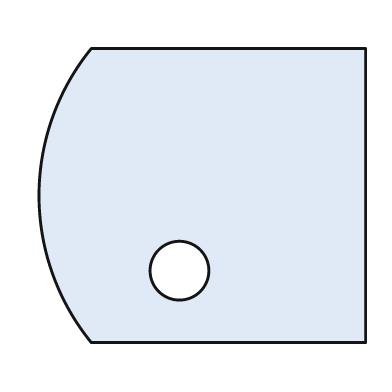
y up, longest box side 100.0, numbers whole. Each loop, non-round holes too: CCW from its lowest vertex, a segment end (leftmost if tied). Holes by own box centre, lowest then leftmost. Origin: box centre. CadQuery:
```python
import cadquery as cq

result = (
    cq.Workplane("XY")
    .moveTo(-34.0, -45.0)
    .lineTo(50.0, -45.0)
    .lineTo(50.0, 45.0)
    .lineTo(-34.0, 45.0)
    .threePointArc((-50.0, 0.0), (-34.0, -45.0))
    .close()
    .moveTo(-7.0, -23.0)
    .circle(9.0)
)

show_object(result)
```